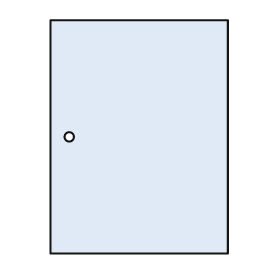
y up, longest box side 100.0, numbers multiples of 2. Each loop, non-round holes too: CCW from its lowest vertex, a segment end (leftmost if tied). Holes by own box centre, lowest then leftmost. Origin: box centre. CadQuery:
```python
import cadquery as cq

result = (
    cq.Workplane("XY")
    .moveTo(-38.0, -50.0)
    .lineTo(38.0, -50.0)
    .lineTo(38.0, 50.0)
    .lineTo(-38.0, 50.0)
    .close()
    .moveTo(-30.0, 0.0)
    .circle(2.0)
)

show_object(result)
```